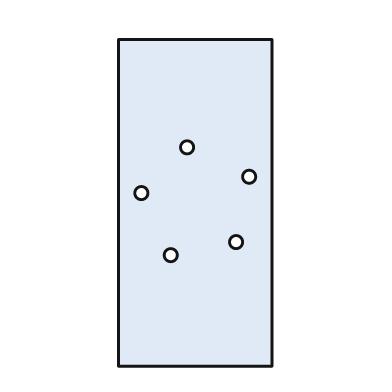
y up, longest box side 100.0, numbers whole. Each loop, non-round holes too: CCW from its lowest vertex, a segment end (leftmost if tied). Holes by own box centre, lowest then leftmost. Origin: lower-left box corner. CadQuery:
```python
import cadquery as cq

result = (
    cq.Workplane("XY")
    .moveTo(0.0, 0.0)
    .lineTo(47.0, 0.0)
    .lineTo(47.0, 100.0)
    .lineTo(0.0, 100.0)
    .close()
    .moveTo(16.0, 34.0)
    .circle(2.0)
    .moveTo(36.0, 38.0)
    .circle(2.0)
    .moveTo(7.0, 53.0)
    .circle(2.0)
    .moveTo(40.0, 58.0)
    .circle(2.0)
    .moveTo(21.0, 67.0)
    .circle(2.0)
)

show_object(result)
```